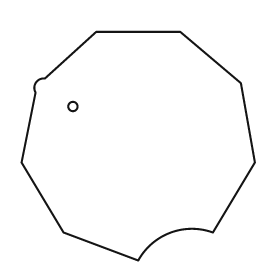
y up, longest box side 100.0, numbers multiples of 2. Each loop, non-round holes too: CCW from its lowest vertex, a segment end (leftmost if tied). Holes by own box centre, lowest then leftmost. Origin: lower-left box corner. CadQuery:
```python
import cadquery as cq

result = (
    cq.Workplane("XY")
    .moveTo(50.0, 0.0)
    .threePointArc((64.0, 12.0), (82.0, 12.0))
    .lineTo(100.0, 42.0)
    .lineTo(94.0, 76.0)
    .lineTo(68.0, 98.0)
    .lineTo(32.0, 98.0)
    .lineTo(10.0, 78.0)
    .threePointArc((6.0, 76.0), (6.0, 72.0))
    .lineTo(0.0, 42.0)
    .lineTo(18.0, 12.0)
    .close()
    .moveTo(22.0, 66.0)
    .circle(2.0)
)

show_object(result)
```